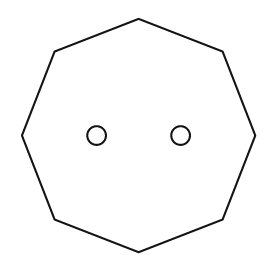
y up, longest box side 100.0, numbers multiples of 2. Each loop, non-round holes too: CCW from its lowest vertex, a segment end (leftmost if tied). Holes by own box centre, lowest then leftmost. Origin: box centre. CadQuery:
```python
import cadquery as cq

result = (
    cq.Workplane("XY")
    .moveTo(0.0, -50.0)
    .lineTo(36.0, -36.0)
    .lineTo(50.0, 0.0)
    .lineTo(36.0, 36.0)
    .lineTo(0.0, 50.0)
    .lineTo(-36.0, 36.0)
    .lineTo(-50.0, 0.0)
    .lineTo(-36.0, -36.0)
    .close()
    .moveTo(-18.0, 0.0)
    .circle(4.0)
    .moveTo(18.0, 0.0)
    .circle(4.0)
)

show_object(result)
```